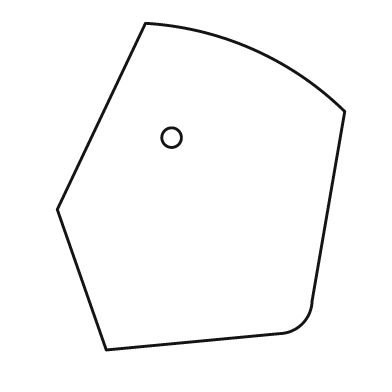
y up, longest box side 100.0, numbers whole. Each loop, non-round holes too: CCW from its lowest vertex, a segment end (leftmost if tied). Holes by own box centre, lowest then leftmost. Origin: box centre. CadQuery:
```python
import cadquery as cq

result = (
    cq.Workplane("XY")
    .moveTo(-29.0, -50.0)
    .lineTo(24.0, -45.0)
    .threePointArc((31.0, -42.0), (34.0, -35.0))
    .lineTo(44.0, 23.0)
    .threePointArc((16.0, 42.0), (-17.0, 50.0))
    .lineTo(-44.0, -7.0)
    .close()
    .moveTo(-9.0, 15.0)
    .circle(3.0)
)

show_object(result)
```